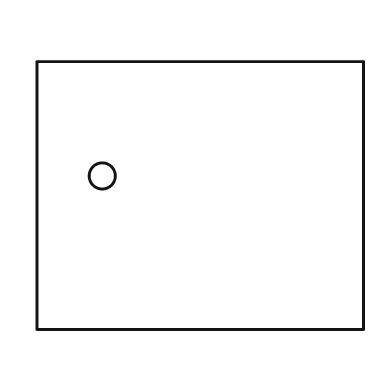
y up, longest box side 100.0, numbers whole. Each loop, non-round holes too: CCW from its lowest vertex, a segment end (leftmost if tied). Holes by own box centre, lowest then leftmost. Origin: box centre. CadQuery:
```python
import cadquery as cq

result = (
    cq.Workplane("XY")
    .moveTo(-50.0, -41.0)
    .lineTo(50.0, -41.0)
    .lineTo(50.0, 41.0)
    .lineTo(-50.0, 41.0)
    .close()
    .moveTo(-30.0, 6.0)
    .circle(4.0)
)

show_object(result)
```